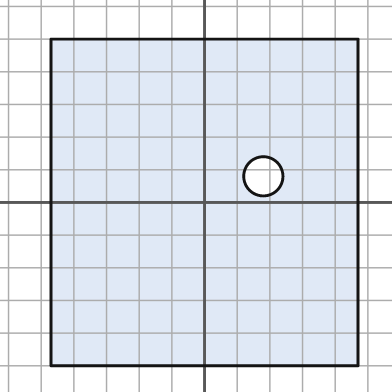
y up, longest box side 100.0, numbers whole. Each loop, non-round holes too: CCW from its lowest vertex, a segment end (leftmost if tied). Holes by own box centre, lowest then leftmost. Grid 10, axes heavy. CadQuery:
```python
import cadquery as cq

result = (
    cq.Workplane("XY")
    .moveTo(-47.0, -50.0)
    .lineTo(47.0, -50.0)
    .lineTo(47.0, 50.0)
    .lineTo(-47.0, 50.0)
    .close()
    .moveTo(18.0, 8.0)
    .circle(6.0)
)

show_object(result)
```